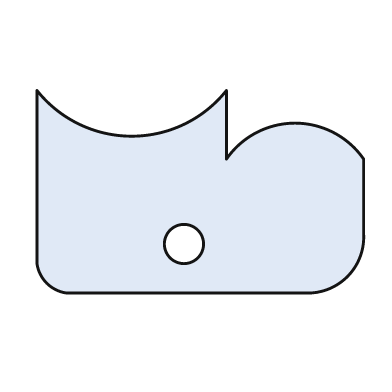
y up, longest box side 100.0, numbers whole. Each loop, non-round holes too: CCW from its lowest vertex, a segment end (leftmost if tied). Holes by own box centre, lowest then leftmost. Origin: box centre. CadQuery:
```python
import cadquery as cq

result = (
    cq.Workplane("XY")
    .moveTo(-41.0, -31.0)
    .lineTo(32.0, -31.0)
    .threePointArc((45.0, -26.0), (50.0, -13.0))
    .lineTo(50.0, 10.0)
    .threePointArc((29.0, 21.0), (8.0, 10.0))
    .lineTo(8.0, 31.0)
    .threePointArc((-21.0, 17.0), (-50.0, 31.0))
    .lineTo(-50.0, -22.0)
    .threePointArc((-47.0, -28.0), (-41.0, -31.0))
    .close()
    .moveTo(-5.0, -16.0)
    .circle(6.0)
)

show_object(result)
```